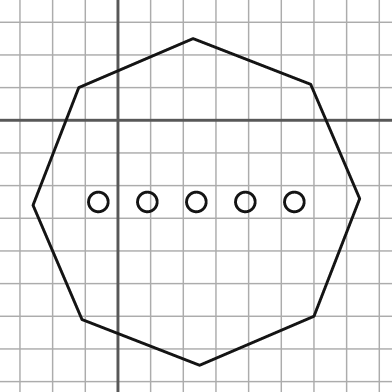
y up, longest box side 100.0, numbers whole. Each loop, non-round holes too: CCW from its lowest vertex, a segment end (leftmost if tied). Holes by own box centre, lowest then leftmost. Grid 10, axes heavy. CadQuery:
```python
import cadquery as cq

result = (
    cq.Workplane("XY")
    .moveTo(25.0, -75.0)
    .lineTo(60.0, -60.0)
    .lineTo(74.0, -24.0)
    .lineTo(59.0, 11.0)
    .lineTo(23.0, 25.0)
    .lineTo(-12.0, 10.0)
    .lineTo(-26.0, -26.0)
    .lineTo(-11.0, -61.0)
    .close()
    .moveTo(-6.0, -25.0)
    .circle(3.0)
    .moveTo(9.0, -25.0)
    .circle(3.0)
    .moveTo(24.0, -25.0)
    .circle(3.0)
    .moveTo(39.0, -25.0)
    .circle(3.0)
    .moveTo(54.0, -25.0)
    .circle(3.0)
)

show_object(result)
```